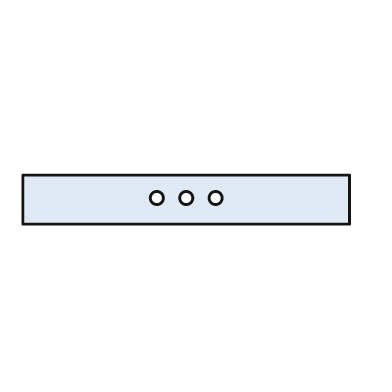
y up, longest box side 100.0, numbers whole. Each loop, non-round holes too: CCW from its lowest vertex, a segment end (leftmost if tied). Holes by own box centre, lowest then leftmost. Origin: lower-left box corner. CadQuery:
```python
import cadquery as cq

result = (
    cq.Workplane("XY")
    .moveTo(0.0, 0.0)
    .lineTo(100.0, 0.0)
    .lineTo(100.0, 15.0)
    .lineTo(0.0, 15.0)
    .close()
    .moveTo(41.0, 8.0)
    .circle(2.0)
    .moveTo(50.0, 8.0)
    .circle(2.0)
    .moveTo(59.0, 8.0)
    .circle(2.0)
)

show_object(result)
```